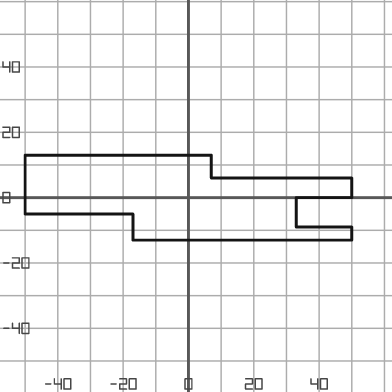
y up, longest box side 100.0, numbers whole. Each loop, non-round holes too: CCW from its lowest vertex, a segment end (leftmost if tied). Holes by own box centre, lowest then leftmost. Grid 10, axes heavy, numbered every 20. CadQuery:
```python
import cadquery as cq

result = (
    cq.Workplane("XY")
    .moveTo(-17.0, -13.0)
    .lineTo(50.0, -13.0)
    .lineTo(50.0, -9.0)
    .lineTo(33.0, -9.0)
    .lineTo(33.0, 0.0)
    .lineTo(50.0, 0.0)
    .lineTo(50.0, 6.0)
    .lineTo(7.0, 6.0)
    .lineTo(7.0, 13.0)
    .lineTo(-50.0, 13.0)
    .lineTo(-50.0, -5.0)
    .lineTo(-17.0, -5.0)
    .close()
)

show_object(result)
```